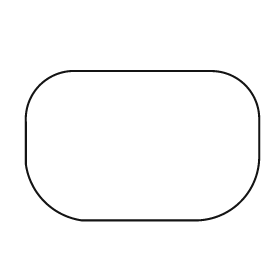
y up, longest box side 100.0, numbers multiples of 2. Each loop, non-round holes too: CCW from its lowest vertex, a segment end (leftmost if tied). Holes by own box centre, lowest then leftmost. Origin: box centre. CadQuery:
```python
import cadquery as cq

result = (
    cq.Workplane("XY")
    .moveTo(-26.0, -32.0)
    .lineTo(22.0, -32.0)
    .threePointArc((42.0, -24.0), (50.0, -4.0))
    .lineTo(50.0, 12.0)
    .threePointArc((44.0, 26.0), (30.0, 32.0))
    .lineTo(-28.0, 32.0)
    .threePointArc((-44.0, 26.0), (-50.0, 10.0))
    .lineTo(-50.0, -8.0)
    .threePointArc((-42.0, -24.0), (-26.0, -32.0))
    .close()
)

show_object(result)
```